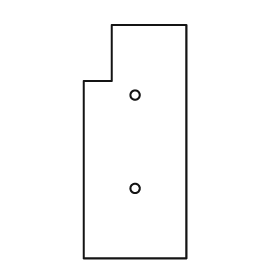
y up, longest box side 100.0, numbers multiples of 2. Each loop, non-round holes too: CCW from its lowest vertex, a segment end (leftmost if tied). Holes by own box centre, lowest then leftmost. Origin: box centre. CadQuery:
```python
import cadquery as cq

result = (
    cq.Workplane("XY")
    .moveTo(-22.0, -50.0)
    .lineTo(22.0, -50.0)
    .lineTo(22.0, 50.0)
    .lineTo(-10.0, 50.0)
    .lineTo(-10.0, 26.0)
    .lineTo(-22.0, 26.0)
    .close()
    .moveTo(0.0, -20.0)
    .circle(2.0)
    .moveTo(0.0, 20.0)
    .circle(2.0)
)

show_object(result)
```